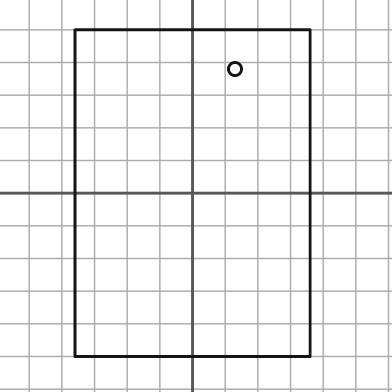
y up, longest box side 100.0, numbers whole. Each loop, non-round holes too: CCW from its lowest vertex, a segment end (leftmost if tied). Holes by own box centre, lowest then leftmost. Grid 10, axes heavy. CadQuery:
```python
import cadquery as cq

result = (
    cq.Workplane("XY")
    .moveTo(-36.0, -50.0)
    .lineTo(36.0, -50.0)
    .lineTo(36.0, 50.0)
    .lineTo(-36.0, 50.0)
    .close()
    .moveTo(13.0, 38.0)
    .circle(2.0)
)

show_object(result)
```